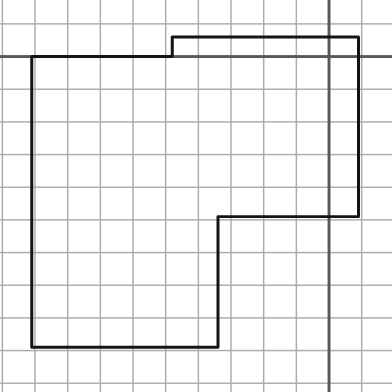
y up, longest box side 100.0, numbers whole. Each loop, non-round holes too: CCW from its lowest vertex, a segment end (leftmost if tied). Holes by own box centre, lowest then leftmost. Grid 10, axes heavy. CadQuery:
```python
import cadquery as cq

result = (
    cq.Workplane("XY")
    .moveTo(-91.0, -89.0)
    .lineTo(-34.0, -89.0)
    .lineTo(-34.0, -49.0)
    .lineTo(9.0, -49.0)
    .lineTo(9.0, 6.0)
    .lineTo(-48.0, 6.0)
    .lineTo(-48.0, 0.0)
    .lineTo(-91.0, 0.0)
    .close()
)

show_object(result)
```